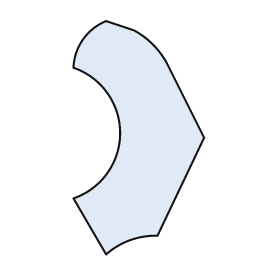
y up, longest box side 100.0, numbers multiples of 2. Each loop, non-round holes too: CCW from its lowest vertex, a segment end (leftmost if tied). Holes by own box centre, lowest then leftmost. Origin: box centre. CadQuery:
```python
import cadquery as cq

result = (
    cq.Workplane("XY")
    .moveTo(-14.0, -50.0)
    .threePointArc((-4.0, -44.0), (8.0, -42.0))
    .lineTo(28.0, 0.0)
    .lineTo(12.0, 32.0)
    .threePointArc((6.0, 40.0), (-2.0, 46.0))
    .lineTo(-14.0, 50.0)
    .threePointArc((-24.0, 42.0), (-28.0, 30.0))
    .threePointArc((-8.0, 2.0), (-28.0, -26.0))
    .close()
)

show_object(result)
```